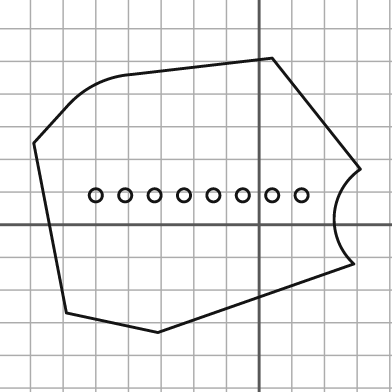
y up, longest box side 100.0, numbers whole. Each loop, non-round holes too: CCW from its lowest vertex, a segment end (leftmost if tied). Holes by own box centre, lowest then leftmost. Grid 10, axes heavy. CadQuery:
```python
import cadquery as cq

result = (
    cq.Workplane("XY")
    .moveTo(-31.0, -33.0)
    .lineTo(29.0, -12.0)
    .threePointArc((23.0, 3.0), (31.0, 17.0))
    .lineTo(4.0, 51.0)
    .lineTo(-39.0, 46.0)
    .threePointArc((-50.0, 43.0), (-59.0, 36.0))
    .lineTo(-69.0, 25.0)
    .lineTo(-59.0, -27.0)
    .close()
    .moveTo(-50.0, 9.0)
    .circle(2.0)
    .moveTo(-41.0, 9.0)
    .circle(2.0)
    .moveTo(-32.0, 9.0)
    .circle(2.0)
    .moveTo(-23.0, 9.0)
    .circle(2.0)
    .moveTo(-14.0, 9.0)
    .circle(2.0)
    .moveTo(-5.0, 9.0)
    .circle(2.0)
    .moveTo(4.0, 9.0)
    .circle(2.0)
    .moveTo(13.0, 9.0)
    .circle(2.0)
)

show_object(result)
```